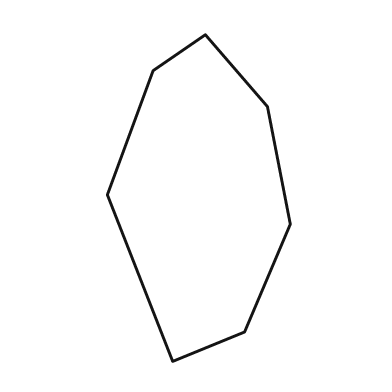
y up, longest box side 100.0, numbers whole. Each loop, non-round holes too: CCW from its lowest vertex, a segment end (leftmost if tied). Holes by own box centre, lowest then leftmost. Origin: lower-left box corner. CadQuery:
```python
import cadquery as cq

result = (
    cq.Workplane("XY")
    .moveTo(20.0, 0.0)
    .lineTo(42.0, 9.0)
    .lineTo(56.0, 42.0)
    .lineTo(49.0, 78.0)
    .lineTo(30.0, 100.0)
    .lineTo(14.0, 89.0)
    .lineTo(0.0, 51.0)
    .close()
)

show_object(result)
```